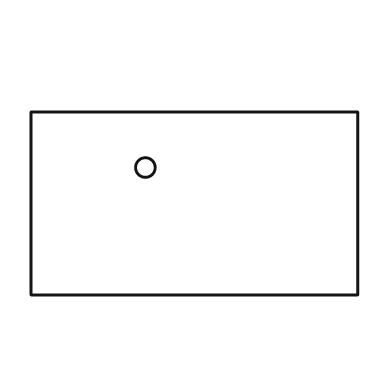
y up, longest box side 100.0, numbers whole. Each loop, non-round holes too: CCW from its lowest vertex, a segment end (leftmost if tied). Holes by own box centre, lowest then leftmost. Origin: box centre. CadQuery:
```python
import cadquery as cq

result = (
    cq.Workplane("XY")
    .moveTo(-50.0, -28.0)
    .lineTo(50.0, -28.0)
    .lineTo(50.0, 28.0)
    .lineTo(-50.0, 28.0)
    .close()
    .moveTo(-15.0, 11.0)
    .circle(3.0)
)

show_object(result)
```